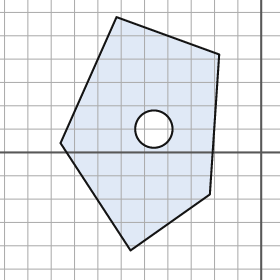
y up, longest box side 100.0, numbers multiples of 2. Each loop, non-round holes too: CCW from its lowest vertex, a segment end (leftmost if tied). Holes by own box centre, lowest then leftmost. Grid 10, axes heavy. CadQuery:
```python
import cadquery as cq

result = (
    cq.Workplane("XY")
    .moveTo(-56.0, -42.0)
    .lineTo(-22.0, -18.0)
    .lineTo(-18.0, 42.0)
    .lineTo(-62.0, 58.0)
    .lineTo(-86.0, 4.0)
    .close()
    .moveTo(-46.0, 10.0)
    .circle(8.0)
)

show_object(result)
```